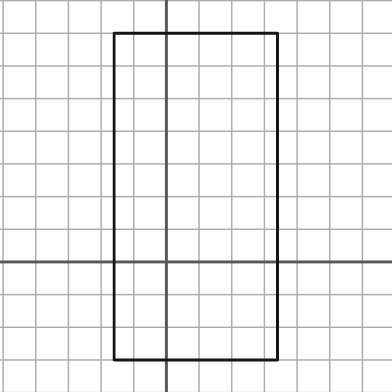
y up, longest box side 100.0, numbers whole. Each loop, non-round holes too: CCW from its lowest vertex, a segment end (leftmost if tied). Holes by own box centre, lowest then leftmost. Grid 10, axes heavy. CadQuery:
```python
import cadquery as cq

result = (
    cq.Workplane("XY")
    .moveTo(-16.0, -30.0)
    .lineTo(34.0, -30.0)
    .lineTo(34.0, 70.0)
    .lineTo(-16.0, 70.0)
    .close()
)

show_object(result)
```